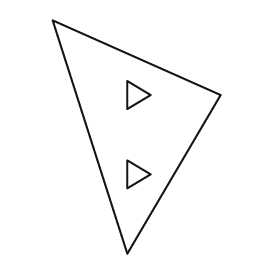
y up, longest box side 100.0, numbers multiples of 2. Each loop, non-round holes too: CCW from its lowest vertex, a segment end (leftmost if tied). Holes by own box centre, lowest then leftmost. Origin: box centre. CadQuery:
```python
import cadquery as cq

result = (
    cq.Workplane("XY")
    .moveTo(-4.0, -50.0)
    .lineTo(36.0, 18.0)
    .lineTo(-36.0, 50.0)
    .close()
    .moveTo(-4.0, -22.0)
    .lineTo(6.0, -16.0)
    .lineTo(-4.0, -10.0)
    .close()
    .moveTo(-4.0, 12.0)
    .lineTo(6.0, 18.0)
    .lineTo(-4.0, 24.0)
    .close()
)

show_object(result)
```